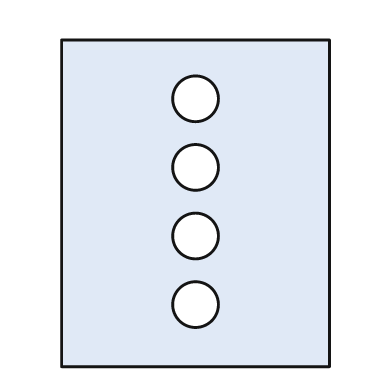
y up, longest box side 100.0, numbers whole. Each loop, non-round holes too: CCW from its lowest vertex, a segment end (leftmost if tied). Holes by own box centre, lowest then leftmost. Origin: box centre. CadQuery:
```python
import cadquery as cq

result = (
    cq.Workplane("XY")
    .moveTo(-41.0, -50.0)
    .lineTo(41.0, -50.0)
    .lineTo(41.0, 50.0)
    .lineTo(-41.0, 50.0)
    .close()
    .moveTo(0.0, -31.0)
    .circle(7.0)
    .moveTo(0.0, -10.0)
    .circle(7.0)
    .moveTo(0.0, 11.0)
    .circle(7.0)
    .moveTo(0.0, 32.0)
    .circle(7.0)
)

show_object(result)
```